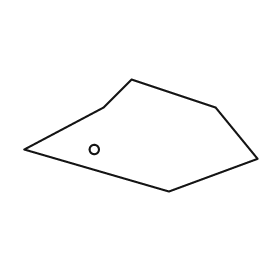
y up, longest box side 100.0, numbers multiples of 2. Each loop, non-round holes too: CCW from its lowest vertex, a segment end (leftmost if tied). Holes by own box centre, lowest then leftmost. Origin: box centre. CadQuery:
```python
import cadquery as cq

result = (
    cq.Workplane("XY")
    .moveTo(12.0, -24.0)
    .lineTo(50.0, -10.0)
    .lineTo(32.0, 12.0)
    .lineTo(-4.0, 24.0)
    .lineTo(-16.0, 12.0)
    .lineTo(-50.0, -6.0)
    .close()
    .moveTo(-20.0, -6.0)
    .circle(2.0)
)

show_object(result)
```